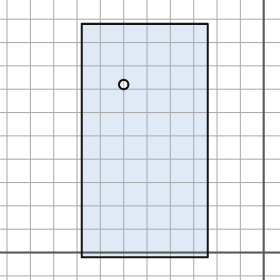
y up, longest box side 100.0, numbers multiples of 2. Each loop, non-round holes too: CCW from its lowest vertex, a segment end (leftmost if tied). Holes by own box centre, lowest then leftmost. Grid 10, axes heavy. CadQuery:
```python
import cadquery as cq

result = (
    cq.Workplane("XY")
    .moveTo(-78.0, -2.0)
    .lineTo(-24.0, -2.0)
    .lineTo(-24.0, 98.0)
    .lineTo(-78.0, 98.0)
    .close()
    .moveTo(-60.0, 72.0)
    .circle(2.0)
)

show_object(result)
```